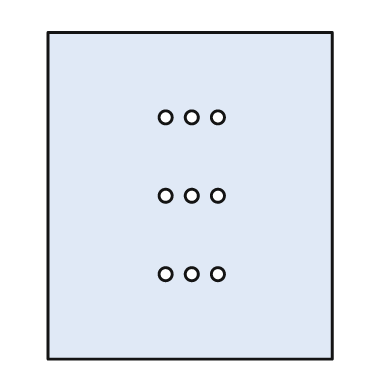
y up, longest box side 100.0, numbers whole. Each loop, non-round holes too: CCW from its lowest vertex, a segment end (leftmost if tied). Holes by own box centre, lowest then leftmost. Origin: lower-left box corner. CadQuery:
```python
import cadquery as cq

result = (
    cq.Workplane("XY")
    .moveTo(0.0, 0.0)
    .lineTo(87.0, 0.0)
    .lineTo(87.0, 100.0)
    .lineTo(0.0, 100.0)
    .close()
    .moveTo(36.0, 26.0)
    .circle(2.0)
    .moveTo(44.0, 26.0)
    .circle(2.0)
    .moveTo(52.0, 26.0)
    .circle(2.0)
    .moveTo(36.0, 50.0)
    .circle(2.0)
    .moveTo(44.0, 50.0)
    .circle(2.0)
    .moveTo(52.0, 50.0)
    .circle(2.0)
    .moveTo(36.0, 74.0)
    .circle(2.0)
    .moveTo(44.0, 74.0)
    .circle(2.0)
    .moveTo(52.0, 74.0)
    .circle(2.0)
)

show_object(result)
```